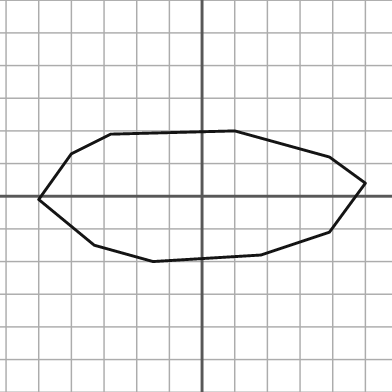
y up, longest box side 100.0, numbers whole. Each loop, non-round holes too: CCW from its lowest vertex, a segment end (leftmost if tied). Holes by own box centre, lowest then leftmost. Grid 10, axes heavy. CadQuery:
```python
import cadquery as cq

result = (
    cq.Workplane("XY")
    .moveTo(-15.0, -20.0)
    .lineTo(18.0, -18.0)
    .lineTo(39.0, -11.0)
    .lineTo(50.0, 4.0)
    .lineTo(39.0, 12.0)
    .lineTo(10.0, 20.0)
    .lineTo(-28.0, 19.0)
    .lineTo(-40.0, 13.0)
    .lineTo(-50.0, -1.0)
    .lineTo(-33.0, -15.0)
    .close()
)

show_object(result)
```